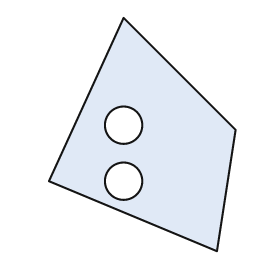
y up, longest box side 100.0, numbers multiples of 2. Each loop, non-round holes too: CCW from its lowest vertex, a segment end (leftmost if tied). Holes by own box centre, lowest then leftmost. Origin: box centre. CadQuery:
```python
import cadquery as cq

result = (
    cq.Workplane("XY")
    .moveTo(32.0, -50.0)
    .lineTo(40.0, 2.0)
    .lineTo(-8.0, 50.0)
    .lineTo(-40.0, -20.0)
    .close()
    .moveTo(-8.0, -20.0)
    .circle(8.0)
    .moveTo(-8.0, 4.0)
    .circle(8.0)
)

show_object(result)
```